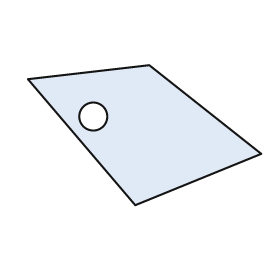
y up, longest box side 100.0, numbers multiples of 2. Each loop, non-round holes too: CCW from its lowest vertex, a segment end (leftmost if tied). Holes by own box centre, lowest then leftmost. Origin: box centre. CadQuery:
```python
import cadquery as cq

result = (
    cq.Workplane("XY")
    .moveTo(-4.0, -30.0)
    .lineTo(50.0, -8.0)
    .lineTo(2.0, 30.0)
    .lineTo(-50.0, 24.0)
    .close()
    .moveTo(-22.0, 8.0)
    .circle(6.0)
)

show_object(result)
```